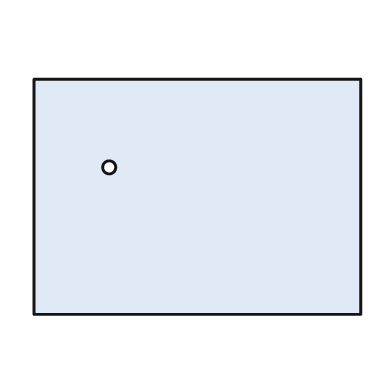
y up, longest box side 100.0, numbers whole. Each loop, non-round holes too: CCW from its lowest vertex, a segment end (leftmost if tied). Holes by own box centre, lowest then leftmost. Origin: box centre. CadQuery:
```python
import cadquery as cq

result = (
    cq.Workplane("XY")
    .moveTo(-50.0, -36.0)
    .lineTo(50.0, -36.0)
    .lineTo(50.0, 36.0)
    .lineTo(-50.0, 36.0)
    .close()
    .moveTo(-27.0, 9.0)
    .circle(2.0)
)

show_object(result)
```